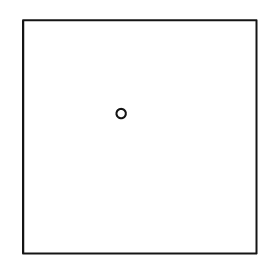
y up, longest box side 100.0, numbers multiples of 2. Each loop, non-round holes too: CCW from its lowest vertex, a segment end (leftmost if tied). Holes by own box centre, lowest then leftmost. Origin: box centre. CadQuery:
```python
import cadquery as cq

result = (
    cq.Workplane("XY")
    .moveTo(-50.0, -50.0)
    .lineTo(50.0, -50.0)
    .lineTo(50.0, 50.0)
    .lineTo(-50.0, 50.0)
    .close()
    .moveTo(-8.0, 10.0)
    .circle(2.0)
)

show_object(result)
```